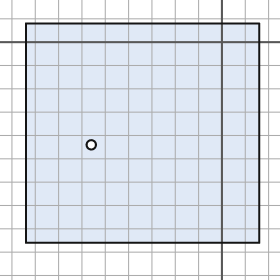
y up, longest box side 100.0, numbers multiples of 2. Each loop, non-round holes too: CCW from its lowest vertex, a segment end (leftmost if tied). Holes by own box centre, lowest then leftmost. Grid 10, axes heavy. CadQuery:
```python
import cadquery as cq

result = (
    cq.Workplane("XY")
    .moveTo(-84.0, -86.0)
    .lineTo(16.0, -86.0)
    .lineTo(16.0, 8.0)
    .lineTo(-84.0, 8.0)
    .close()
    .moveTo(-56.0, -44.0)
    .circle(2.0)
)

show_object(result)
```